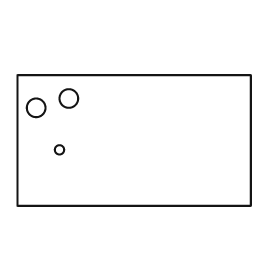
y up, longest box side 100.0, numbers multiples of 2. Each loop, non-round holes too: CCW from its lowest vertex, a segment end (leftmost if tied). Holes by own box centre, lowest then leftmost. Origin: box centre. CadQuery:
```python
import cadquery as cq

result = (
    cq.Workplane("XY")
    .moveTo(-50.0, -28.0)
    .lineTo(50.0, -28.0)
    .lineTo(50.0, 28.0)
    .lineTo(-50.0, 28.0)
    .close()
    .moveTo(-32.0, -4.0)
    .circle(2.0)
    .moveTo(-42.0, 14.0)
    .circle(4.0)
    .moveTo(-28.0, 18.0)
    .circle(4.0)
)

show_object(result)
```